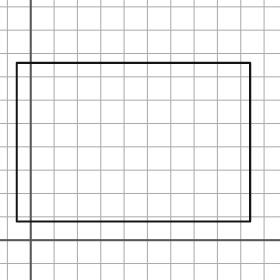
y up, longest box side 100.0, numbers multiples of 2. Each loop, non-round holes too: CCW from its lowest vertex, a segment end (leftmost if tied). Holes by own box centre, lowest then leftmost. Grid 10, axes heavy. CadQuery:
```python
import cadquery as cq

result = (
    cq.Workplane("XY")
    .moveTo(-6.0, 8.0)
    .lineTo(94.0, 8.0)
    .lineTo(94.0, 76.0)
    .lineTo(-6.0, 76.0)
    .close()
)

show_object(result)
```